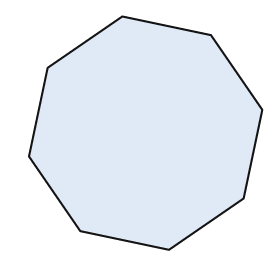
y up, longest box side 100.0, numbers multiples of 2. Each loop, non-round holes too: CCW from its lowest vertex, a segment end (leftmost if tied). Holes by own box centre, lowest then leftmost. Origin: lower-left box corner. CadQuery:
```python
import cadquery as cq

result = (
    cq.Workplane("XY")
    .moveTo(60.0, 0.0)
    .lineTo(92.0, 22.0)
    .lineTo(100.0, 60.0)
    .lineTo(78.0, 92.0)
    .lineTo(40.0, 100.0)
    .lineTo(8.0, 78.0)
    .lineTo(0.0, 40.0)
    .lineTo(22.0, 8.0)
    .close()
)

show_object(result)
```